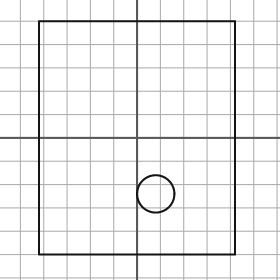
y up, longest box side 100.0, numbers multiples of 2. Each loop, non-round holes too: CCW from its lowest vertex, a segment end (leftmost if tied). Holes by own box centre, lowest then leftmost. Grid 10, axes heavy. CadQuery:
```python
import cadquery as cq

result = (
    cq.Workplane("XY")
    .moveTo(-42.0, -50.0)
    .lineTo(42.0, -50.0)
    .lineTo(42.0, 50.0)
    .lineTo(-42.0, 50.0)
    .close()
    .moveTo(8.0, -24.0)
    .circle(8.0)
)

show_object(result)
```